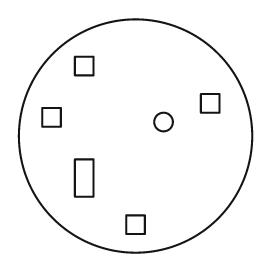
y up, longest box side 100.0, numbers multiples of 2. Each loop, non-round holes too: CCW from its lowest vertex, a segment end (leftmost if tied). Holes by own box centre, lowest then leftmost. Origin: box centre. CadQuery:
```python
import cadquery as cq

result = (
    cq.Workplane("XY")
    .moveTo(0.0, 0.0)
    .circle(50.0)
    .moveTo(-4.0, -42.0)
    .lineTo(4.0, -42.0)
    .lineTo(4.0, -34.0)
    .lineTo(-4.0, -34.0)
    .close()
    .moveTo(-26.0, -26.0)
    .lineTo(-18.0, -26.0)
    .lineTo(-18.0, -10.0)
    .lineTo(-26.0, -10.0)
    .close()
    .moveTo(12.0, 6.0)
    .circle(4.0)
    .moveTo(-40.0, 4.0)
    .lineTo(-32.0, 4.0)
    .lineTo(-32.0, 12.0)
    .lineTo(-40.0, 12.0)
    .close()
    .moveTo(28.0, 10.0)
    .lineTo(36.0, 10.0)
    .lineTo(36.0, 18.0)
    .lineTo(28.0, 18.0)
    .close()
    .moveTo(-26.0, 26.0)
    .lineTo(-18.0, 26.0)
    .lineTo(-18.0, 34.0)
    .lineTo(-26.0, 34.0)
    .close()
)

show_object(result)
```